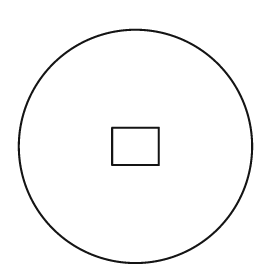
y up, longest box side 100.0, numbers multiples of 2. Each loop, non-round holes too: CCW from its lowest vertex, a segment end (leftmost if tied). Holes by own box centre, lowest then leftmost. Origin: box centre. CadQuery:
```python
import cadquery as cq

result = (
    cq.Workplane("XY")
    .moveTo(0.0, 0.0)
    .circle(50.0)
    .moveTo(-10.0, -8.0)
    .lineTo(10.0, -8.0)
    .lineTo(10.0, 8.0)
    .lineTo(-10.0, 8.0)
    .close()
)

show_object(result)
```